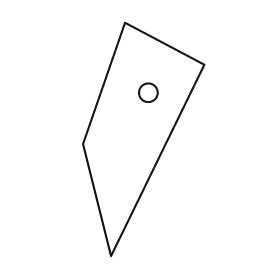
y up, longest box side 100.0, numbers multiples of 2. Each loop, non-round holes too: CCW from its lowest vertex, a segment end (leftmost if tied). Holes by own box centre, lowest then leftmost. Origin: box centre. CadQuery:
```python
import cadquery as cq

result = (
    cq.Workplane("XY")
    .moveTo(-14.0, -50.0)
    .lineTo(26.0, 32.0)
    .lineTo(-8.0, 50.0)
    .lineTo(-26.0, -2.0)
    .close()
    .moveTo(2.0, 20.0)
    .circle(4.0)
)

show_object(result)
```